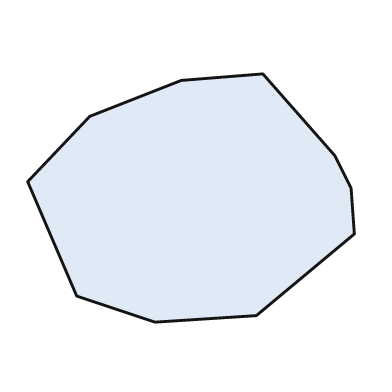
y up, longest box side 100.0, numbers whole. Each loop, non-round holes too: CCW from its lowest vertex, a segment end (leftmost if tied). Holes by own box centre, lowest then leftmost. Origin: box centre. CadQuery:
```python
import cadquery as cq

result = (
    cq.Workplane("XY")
    .moveTo(-11.0, -38.0)
    .lineTo(20.0, -36.0)
    .lineTo(50.0, -11.0)
    .lineTo(49.0, 3.0)
    .lineTo(44.0, 13.0)
    .lineTo(22.0, 38.0)
    .lineTo(-3.0, 36.0)
    .lineTo(-31.0, 25.0)
    .lineTo(-50.0, 5.0)
    .lineTo(-35.0, -30.0)
    .close()
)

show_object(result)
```